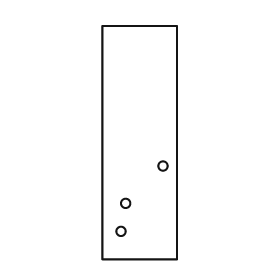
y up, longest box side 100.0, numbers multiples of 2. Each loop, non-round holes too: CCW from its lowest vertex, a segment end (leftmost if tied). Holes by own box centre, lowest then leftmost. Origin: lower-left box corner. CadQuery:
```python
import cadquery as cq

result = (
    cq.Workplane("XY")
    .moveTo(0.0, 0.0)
    .lineTo(32.0, 0.0)
    .lineTo(32.0, 100.0)
    .lineTo(0.0, 100.0)
    .close()
    .moveTo(8.0, 12.0)
    .circle(2.0)
    .moveTo(10.0, 24.0)
    .circle(2.0)
    .moveTo(26.0, 40.0)
    .circle(2.0)
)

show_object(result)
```